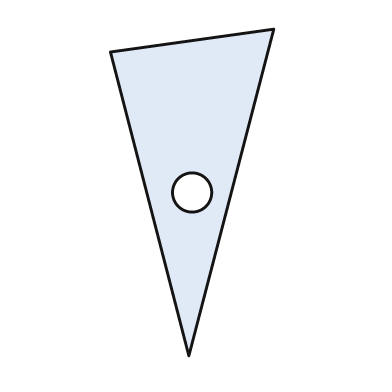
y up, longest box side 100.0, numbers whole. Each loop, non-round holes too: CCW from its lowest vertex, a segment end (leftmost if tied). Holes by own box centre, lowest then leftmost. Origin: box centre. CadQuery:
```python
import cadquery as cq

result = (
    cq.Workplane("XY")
    .moveTo(-1.0, -50.0)
    .lineTo(25.0, 50.0)
    .lineTo(-25.0, 43.0)
    .close()
    .moveTo(0.0, 0.0)
    .circle(6.0)
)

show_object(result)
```